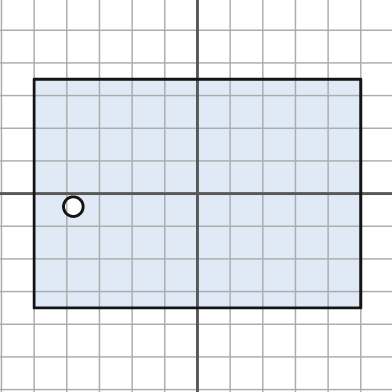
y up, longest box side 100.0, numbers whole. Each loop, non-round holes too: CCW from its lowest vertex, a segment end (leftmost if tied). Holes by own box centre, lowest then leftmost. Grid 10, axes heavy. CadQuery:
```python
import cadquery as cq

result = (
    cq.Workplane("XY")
    .moveTo(-50.0, -35.0)
    .lineTo(50.0, -35.0)
    .lineTo(50.0, 35.0)
    .lineTo(-50.0, 35.0)
    .close()
    .moveTo(-38.0, -4.0)
    .circle(3.0)
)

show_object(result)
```